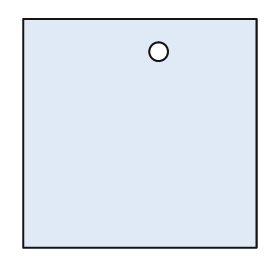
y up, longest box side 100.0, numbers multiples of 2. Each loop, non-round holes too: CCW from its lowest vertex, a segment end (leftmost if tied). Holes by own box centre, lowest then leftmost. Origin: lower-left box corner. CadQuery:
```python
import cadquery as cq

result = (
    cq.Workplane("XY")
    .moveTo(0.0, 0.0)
    .lineTo(100.0, 0.0)
    .lineTo(100.0, 98.0)
    .lineTo(0.0, 98.0)
    .close()
    .moveTo(58.0, 84.0)
    .circle(4.0)
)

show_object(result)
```